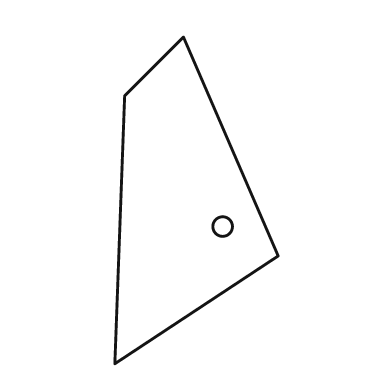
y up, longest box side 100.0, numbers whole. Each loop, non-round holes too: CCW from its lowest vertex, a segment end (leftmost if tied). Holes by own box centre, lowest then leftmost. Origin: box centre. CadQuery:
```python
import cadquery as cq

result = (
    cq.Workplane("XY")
    .moveTo(-25.0, -50.0)
    .lineTo(25.0, -17.0)
    .lineTo(-4.0, 50.0)
    .lineTo(-22.0, 32.0)
    .close()
    .moveTo(8.0, -8.0)
    .circle(3.0)
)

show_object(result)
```